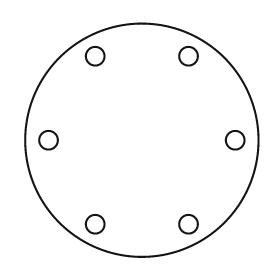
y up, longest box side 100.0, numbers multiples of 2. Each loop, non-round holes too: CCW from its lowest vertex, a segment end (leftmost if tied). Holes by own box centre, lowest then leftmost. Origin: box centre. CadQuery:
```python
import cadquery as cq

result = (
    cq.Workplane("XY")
    .moveTo(0.0, 0.0)
    .circle(50.0)
    .moveTo(-20.0, -36.0)
    .circle(4.0)
    .moveTo(20.0, -36.0)
    .circle(4.0)
    .moveTo(-40.0, 0.0)
    .circle(4.0)
    .moveTo(40.0, 0.0)
    .circle(4.0)
    .moveTo(-20.0, 36.0)
    .circle(4.0)
    .moveTo(20.0, 36.0)
    .circle(4.0)
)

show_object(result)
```